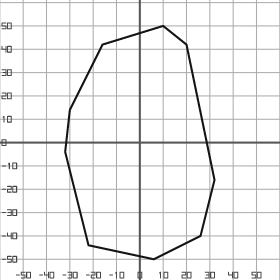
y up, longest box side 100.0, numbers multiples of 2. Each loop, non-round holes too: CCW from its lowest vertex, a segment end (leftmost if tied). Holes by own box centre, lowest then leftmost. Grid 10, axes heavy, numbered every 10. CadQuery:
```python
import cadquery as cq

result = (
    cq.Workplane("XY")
    .moveTo(6.0, -50.0)
    .lineTo(26.0, -40.0)
    .lineTo(32.0, -16.0)
    .lineTo(20.0, 42.0)
    .lineTo(10.0, 50.0)
    .lineTo(-16.0, 42.0)
    .lineTo(-30.0, 14.0)
    .lineTo(-32.0, -4.0)
    .lineTo(-22.0, -44.0)
    .close()
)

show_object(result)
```